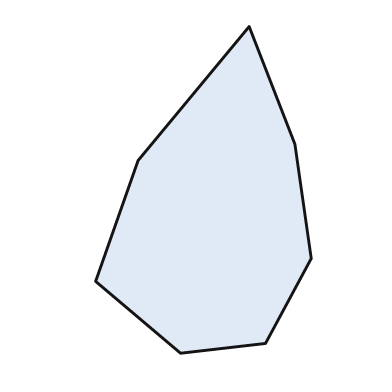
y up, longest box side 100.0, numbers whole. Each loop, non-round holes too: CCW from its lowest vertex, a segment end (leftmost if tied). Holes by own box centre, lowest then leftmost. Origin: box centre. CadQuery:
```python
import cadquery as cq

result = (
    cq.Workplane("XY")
    .moveTo(-7.0, -50.0)
    .lineTo(19.0, -47.0)
    .lineTo(33.0, -21.0)
    .lineTo(28.0, 14.0)
    .lineTo(14.0, 50.0)
    .lineTo(-20.0, 9.0)
    .lineTo(-33.0, -28.0)
    .close()
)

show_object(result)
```